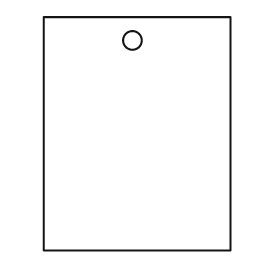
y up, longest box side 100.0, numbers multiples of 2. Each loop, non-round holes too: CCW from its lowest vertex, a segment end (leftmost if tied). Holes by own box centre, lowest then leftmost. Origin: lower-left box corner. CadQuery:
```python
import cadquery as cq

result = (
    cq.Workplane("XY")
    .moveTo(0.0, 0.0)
    .lineTo(80.0, 0.0)
    .lineTo(80.0, 100.0)
    .lineTo(0.0, 100.0)
    .close()
    .moveTo(38.0, 90.0)
    .circle(4.0)
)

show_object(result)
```